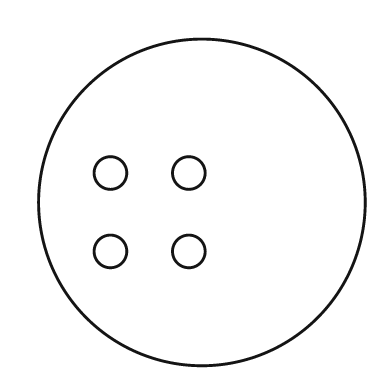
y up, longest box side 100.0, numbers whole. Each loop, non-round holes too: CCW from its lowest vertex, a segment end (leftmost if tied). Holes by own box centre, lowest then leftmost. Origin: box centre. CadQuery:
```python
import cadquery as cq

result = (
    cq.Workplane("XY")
    .moveTo(0.0, 0.0)
    .circle(50.0)
    .moveTo(-28.0, -15.0)
    .circle(5.0)
    .moveTo(-4.0, -15.0)
    .circle(5.0)
    .moveTo(-28.0, 9.0)
    .circle(5.0)
    .moveTo(-4.0, 9.0)
    .circle(5.0)
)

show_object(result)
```